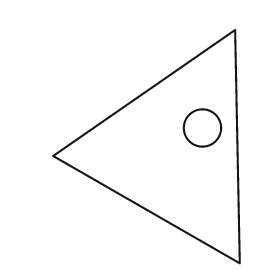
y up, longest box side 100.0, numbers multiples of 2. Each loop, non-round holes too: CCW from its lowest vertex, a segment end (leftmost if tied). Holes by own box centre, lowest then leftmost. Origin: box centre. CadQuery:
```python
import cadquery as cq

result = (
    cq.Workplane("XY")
    .moveTo(40.0, -50.0)
    .lineTo(38.0, 50.0)
    .lineTo(-40.0, -4.0)
    .close()
    .moveTo(24.0, 8.0)
    .circle(8.0)
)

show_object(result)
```